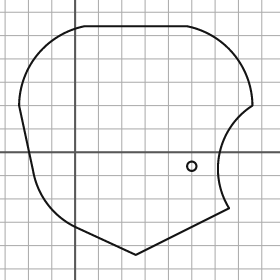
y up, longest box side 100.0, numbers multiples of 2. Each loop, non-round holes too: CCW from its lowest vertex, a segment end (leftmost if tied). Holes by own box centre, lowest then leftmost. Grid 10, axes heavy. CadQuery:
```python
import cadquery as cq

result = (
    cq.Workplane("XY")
    .moveTo(26.0, -44.0)
    .lineTo(66.0, -24.0)
    .threePointArc((62.0, 0.0), (76.0, 20.0))
    .threePointArc((68.0, 42.0), (48.0, 54.0))
    .lineTo(4.0, 54.0)
    .threePointArc((-16.0, 42.0), (-24.0, 20.0))
    .lineTo(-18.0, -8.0)
    .threePointArc((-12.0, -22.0), (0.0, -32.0))
    .close()
    .moveTo(50.0, -6.0)
    .circle(2.0)
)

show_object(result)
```